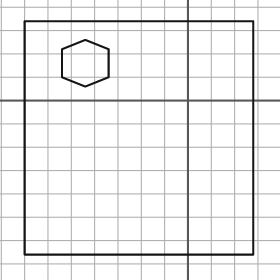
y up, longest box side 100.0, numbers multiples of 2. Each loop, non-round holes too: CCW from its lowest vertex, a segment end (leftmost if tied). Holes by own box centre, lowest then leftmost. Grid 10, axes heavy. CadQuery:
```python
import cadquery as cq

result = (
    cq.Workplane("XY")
    .moveTo(-70.0, -66.0)
    .lineTo(28.0, -66.0)
    .lineTo(28.0, 34.0)
    .lineTo(-70.0, 34.0)
    .close()
    .moveTo(-44.0, 6.0)
    .lineTo(-34.0, 10.0)
    .lineTo(-34.0, 22.0)
    .lineTo(-44.0, 26.0)
    .lineTo(-54.0, 22.0)
    .lineTo(-54.0, 10.0)
    .close()
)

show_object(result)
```